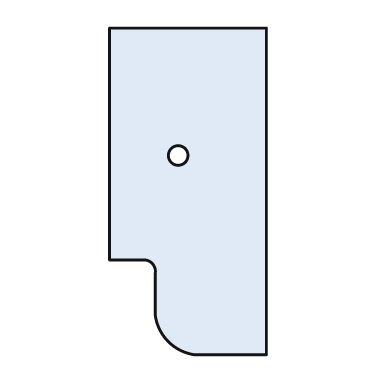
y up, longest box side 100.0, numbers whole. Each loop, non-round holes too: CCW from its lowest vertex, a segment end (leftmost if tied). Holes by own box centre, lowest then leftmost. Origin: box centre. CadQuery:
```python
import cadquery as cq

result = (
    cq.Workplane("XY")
    .moveTo(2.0, -50.0)
    .lineTo(24.0, -50.0)
    .lineTo(24.0, 50.0)
    .lineTo(-24.0, 50.0)
    .lineTo(-24.0, -21.0)
    .lineTo(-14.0, -21.0)
    .threePointArc((-11.0, -22.0), (-10.0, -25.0))
    .lineTo(-10.0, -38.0)
    .threePointArc((-6.0, -46.0), (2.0, -50.0))
    .close()
    .moveTo(-3.0, 11.0)
    .circle(3.0)
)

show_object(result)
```